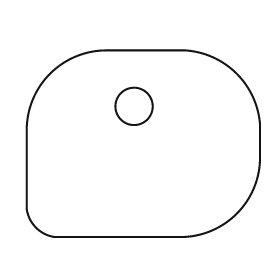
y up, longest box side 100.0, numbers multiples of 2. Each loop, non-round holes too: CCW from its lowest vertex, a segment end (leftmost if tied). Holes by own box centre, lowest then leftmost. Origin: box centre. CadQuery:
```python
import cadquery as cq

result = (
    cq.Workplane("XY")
    .moveTo(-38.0, -40.0)
    .lineTo(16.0, -40.0)
    .threePointArc((40.0, -30.0), (50.0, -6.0))
    .lineTo(50.0, 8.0)
    .threePointArc((40.0, 30.0), (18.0, 40.0))
    .lineTo(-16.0, 40.0)
    .threePointArc((-40.0, 30.0), (-50.0, 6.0))
    .lineTo(-50.0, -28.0)
    .threePointArc((-46.0, -36.0), (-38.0, -40.0))
    .close()
    .moveTo(-4.0, 16.0)
    .circle(8.0)
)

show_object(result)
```